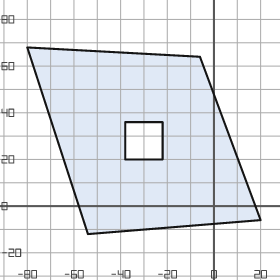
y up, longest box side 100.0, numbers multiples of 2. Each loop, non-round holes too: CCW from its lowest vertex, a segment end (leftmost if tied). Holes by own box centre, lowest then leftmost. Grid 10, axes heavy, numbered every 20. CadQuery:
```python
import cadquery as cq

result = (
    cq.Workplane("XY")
    .moveTo(-54.0, -12.0)
    .lineTo(20.0, -6.0)
    .lineTo(-6.0, 64.0)
    .lineTo(-80.0, 68.0)
    .close()
    .moveTo(-38.0, 20.0)
    .lineTo(-22.0, 20.0)
    .lineTo(-22.0, 36.0)
    .lineTo(-38.0, 36.0)
    .close()
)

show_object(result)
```